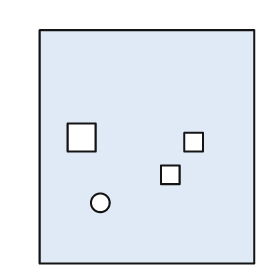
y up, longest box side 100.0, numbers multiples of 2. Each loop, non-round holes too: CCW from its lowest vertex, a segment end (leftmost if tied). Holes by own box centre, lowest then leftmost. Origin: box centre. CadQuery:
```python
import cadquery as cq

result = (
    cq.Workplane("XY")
    .moveTo(-46.0, -50.0)
    .lineTo(46.0, -50.0)
    .lineTo(46.0, 50.0)
    .lineTo(-46.0, 50.0)
    .close()
    .moveTo(-20.0, -24.0)
    .circle(4.0)
    .moveTo(6.0, -16.0)
    .lineTo(14.0, -16.0)
    .lineTo(14.0, -8.0)
    .lineTo(6.0, -8.0)
    .close()
    .moveTo(16.0, -2.0)
    .lineTo(24.0, -2.0)
    .lineTo(24.0, 6.0)
    .lineTo(16.0, 6.0)
    .close()
    .moveTo(-34.0, -2.0)
    .lineTo(-22.0, -2.0)
    .lineTo(-22.0, 10.0)
    .lineTo(-34.0, 10.0)
    .close()
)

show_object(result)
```